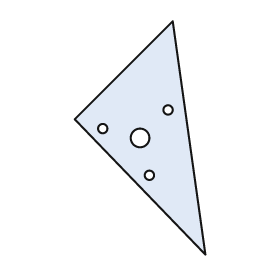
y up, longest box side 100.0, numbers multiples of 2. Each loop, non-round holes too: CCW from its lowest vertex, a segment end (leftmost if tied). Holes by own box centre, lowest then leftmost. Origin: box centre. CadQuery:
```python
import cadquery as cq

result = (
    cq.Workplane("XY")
    .moveTo(28.0, -50.0)
    .lineTo(14.0, 50.0)
    .lineTo(-28.0, 8.0)
    .close()
    .moveTo(4.0, -16.0)
    .circle(2.0)
    .moveTo(0.0, 0.0)
    .circle(4.0)
    .moveTo(-16.0, 4.0)
    .circle(2.0)
    .moveTo(12.0, 12.0)
    .circle(2.0)
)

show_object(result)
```